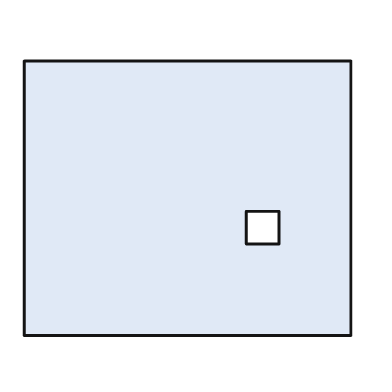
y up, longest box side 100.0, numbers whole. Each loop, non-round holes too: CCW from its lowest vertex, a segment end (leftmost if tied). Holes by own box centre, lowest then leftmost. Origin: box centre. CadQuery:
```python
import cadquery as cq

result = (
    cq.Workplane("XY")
    .moveTo(-50.0, -42.0)
    .lineTo(50.0, -42.0)
    .lineTo(50.0, 42.0)
    .lineTo(-50.0, 42.0)
    .close()
    .moveTo(18.0, -14.0)
    .lineTo(28.0, -14.0)
    .lineTo(28.0, -4.0)
    .lineTo(18.0, -4.0)
    .close()
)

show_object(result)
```